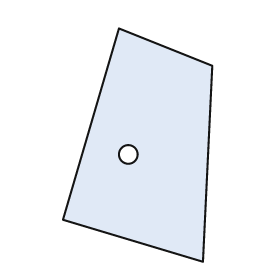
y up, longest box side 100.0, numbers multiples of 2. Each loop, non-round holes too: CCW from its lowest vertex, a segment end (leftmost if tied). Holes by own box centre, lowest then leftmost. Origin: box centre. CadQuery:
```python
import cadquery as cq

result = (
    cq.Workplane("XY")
    .moveTo(28.0, -50.0)
    .lineTo(32.0, 34.0)
    .lineTo(-8.0, 50.0)
    .lineTo(-32.0, -32.0)
    .close()
    .moveTo(-4.0, -4.0)
    .circle(4.0)
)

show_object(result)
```